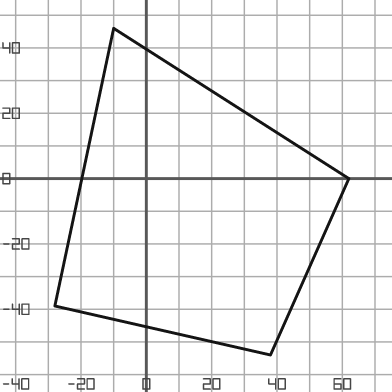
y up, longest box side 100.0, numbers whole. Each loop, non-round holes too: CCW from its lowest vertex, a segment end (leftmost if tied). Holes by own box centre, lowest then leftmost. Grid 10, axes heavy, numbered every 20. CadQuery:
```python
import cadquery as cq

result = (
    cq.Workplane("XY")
    .moveTo(38.0, -54.0)
    .lineTo(62.0, 0.0)
    .lineTo(-10.0, 46.0)
    .lineTo(-28.0, -39.0)
    .close()
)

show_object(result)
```